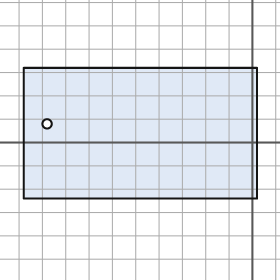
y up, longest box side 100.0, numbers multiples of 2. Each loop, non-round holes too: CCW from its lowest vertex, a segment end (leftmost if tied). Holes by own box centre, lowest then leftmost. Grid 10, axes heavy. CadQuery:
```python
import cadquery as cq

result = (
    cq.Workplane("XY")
    .moveTo(-98.0, -24.0)
    .lineTo(2.0, -24.0)
    .lineTo(2.0, 32.0)
    .lineTo(-98.0, 32.0)
    .close()
    .moveTo(-88.0, 8.0)
    .circle(2.0)
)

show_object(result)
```